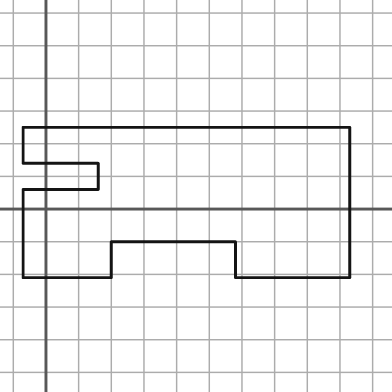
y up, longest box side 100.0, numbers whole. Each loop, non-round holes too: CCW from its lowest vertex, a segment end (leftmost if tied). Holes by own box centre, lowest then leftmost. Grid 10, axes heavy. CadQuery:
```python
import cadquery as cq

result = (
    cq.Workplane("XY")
    .moveTo(-7.0, -21.0)
    .lineTo(20.0, -21.0)
    .lineTo(20.0, -10.0)
    .lineTo(58.0, -10.0)
    .lineTo(58.0, -21.0)
    .lineTo(93.0, -21.0)
    .lineTo(93.0, 25.0)
    .lineTo(-7.0, 25.0)
    .lineTo(-7.0, 14.0)
    .lineTo(16.0, 14.0)
    .lineTo(16.0, 6.0)
    .lineTo(-7.0, 6.0)
    .close()
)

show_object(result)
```